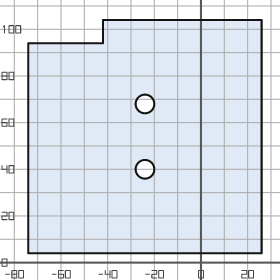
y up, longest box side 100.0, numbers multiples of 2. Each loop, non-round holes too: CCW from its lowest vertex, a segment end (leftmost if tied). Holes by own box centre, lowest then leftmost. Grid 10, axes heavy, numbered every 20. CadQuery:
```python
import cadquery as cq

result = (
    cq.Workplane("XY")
    .moveTo(-74.0, 4.0)
    .lineTo(26.0, 4.0)
    .lineTo(26.0, 104.0)
    .lineTo(-42.0, 104.0)
    .lineTo(-42.0, 94.0)
    .lineTo(-74.0, 94.0)
    .close()
    .moveTo(-24.0, 40.0)
    .circle(4.0)
    .moveTo(-24.0, 68.0)
    .circle(4.0)
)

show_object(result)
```